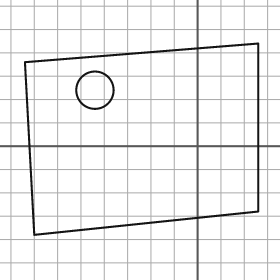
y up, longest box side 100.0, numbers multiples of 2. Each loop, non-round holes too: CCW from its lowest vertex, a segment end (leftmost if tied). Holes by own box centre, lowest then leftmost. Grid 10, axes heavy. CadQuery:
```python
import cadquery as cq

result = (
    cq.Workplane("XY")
    .moveTo(-70.0, -38.0)
    .lineTo(26.0, -28.0)
    .lineTo(26.0, 44.0)
    .lineTo(-74.0, 36.0)
    .close()
    .moveTo(-44.0, 24.0)
    .circle(8.0)
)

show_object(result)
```